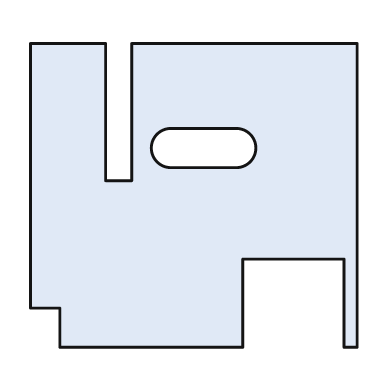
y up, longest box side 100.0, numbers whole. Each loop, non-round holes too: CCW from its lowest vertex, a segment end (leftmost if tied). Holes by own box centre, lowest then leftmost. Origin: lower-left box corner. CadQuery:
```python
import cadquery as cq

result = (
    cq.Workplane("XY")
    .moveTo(9.0, 0.0)
    .lineTo(65.0, 0.0)
    .lineTo(65.0, 27.0)
    .lineTo(96.0, 27.0)
    .lineTo(96.0, 0.0)
    .lineTo(100.0, 0.0)
    .lineTo(100.0, 93.0)
    .lineTo(31.0, 93.0)
    .lineTo(31.0, 51.0)
    .lineTo(23.0, 51.0)
    .lineTo(23.0, 93.0)
    .lineTo(0.0, 93.0)
    .lineTo(0.0, 12.0)
    .lineTo(9.0, 12.0)
    .close()
    .moveTo(43.0, 55.0)
    .lineTo(63.0, 55.0)
    .threePointArc((69.0, 61.0), (63.0, 67.0))
    .lineTo(43.0, 67.0)
    .threePointArc((37.0, 61.0), (43.0, 55.0))
    .close()
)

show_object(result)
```